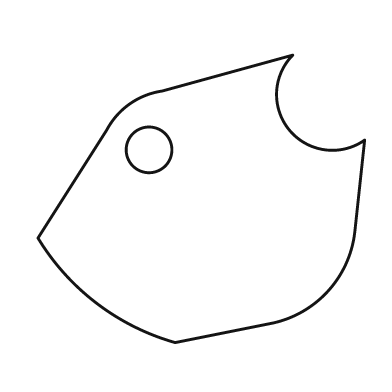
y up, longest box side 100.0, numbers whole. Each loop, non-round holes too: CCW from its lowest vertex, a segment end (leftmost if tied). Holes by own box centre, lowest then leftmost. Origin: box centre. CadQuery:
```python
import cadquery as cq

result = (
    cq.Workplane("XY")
    .moveTo(-8.0, -44.0)
    .lineTo(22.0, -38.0)
    .threePointArc((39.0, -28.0), (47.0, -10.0))
    .lineTo(50.0, 18.0)
    .threePointArc((27.0, 21.0), (28.0, 44.0))
    .lineTo(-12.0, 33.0)
    .threePointArc((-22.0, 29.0), (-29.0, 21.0))
    .lineTo(-50.0, -12.0)
    .threePointArc((-32.0, -32.0), (-8.0, -44.0))
    .close()
    .moveTo(-16.0, 15.0)
    .circle(7.0)
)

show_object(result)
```